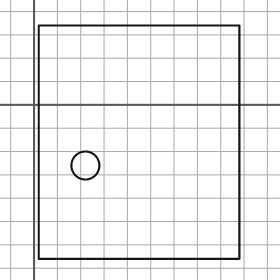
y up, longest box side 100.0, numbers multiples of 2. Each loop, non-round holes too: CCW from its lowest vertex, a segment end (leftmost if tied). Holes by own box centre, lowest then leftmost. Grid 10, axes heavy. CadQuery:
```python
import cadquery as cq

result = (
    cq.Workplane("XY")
    .moveTo(2.0, -66.0)
    .lineTo(88.0, -66.0)
    .lineTo(88.0, 34.0)
    .lineTo(2.0, 34.0)
    .close()
    .moveTo(22.0, -26.0)
    .circle(6.0)
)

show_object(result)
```